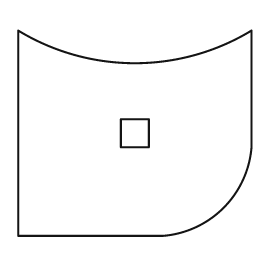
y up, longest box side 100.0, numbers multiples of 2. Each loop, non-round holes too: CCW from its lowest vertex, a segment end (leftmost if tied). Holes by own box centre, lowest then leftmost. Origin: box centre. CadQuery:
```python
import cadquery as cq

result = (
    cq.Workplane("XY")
    .moveTo(-50.0, -44.0)
    .lineTo(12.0, -44.0)
    .threePointArc((38.0, -32.0), (50.0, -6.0))
    .lineTo(50.0, 44.0)
    .threePointArc((0.0, 30.0), (-50.0, 44.0))
    .close()
    .moveTo(-6.0, -6.0)
    .lineTo(6.0, -6.0)
    .lineTo(6.0, 6.0)
    .lineTo(-6.0, 6.0)
    .close()
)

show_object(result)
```